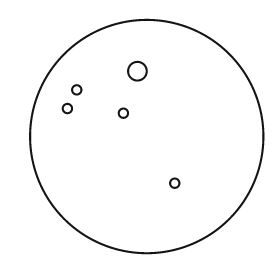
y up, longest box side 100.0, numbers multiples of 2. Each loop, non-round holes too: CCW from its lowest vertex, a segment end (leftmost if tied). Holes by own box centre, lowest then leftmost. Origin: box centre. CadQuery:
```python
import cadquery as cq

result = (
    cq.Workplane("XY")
    .moveTo(0.0, 0.0)
    .circle(50.0)
    .moveTo(12.0, -20.0)
    .circle(2.0)
    .moveTo(-10.0, 10.0)
    .circle(2.0)
    .moveTo(-34.0, 12.0)
    .circle(2.0)
    .moveTo(-30.0, 20.0)
    .circle(2.0)
    .moveTo(-4.0, 28.0)
    .circle(4.0)
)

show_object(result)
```